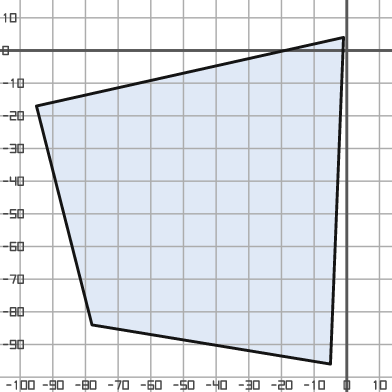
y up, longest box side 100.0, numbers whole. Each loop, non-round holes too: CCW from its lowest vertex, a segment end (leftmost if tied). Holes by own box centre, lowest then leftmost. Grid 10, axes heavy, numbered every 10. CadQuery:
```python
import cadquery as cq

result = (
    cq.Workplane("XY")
    .moveTo(-5.0, -96.0)
    .lineTo(-1.0, 4.0)
    .lineTo(-95.0, -17.0)
    .lineTo(-78.0, -84.0)
    .close()
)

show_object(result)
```